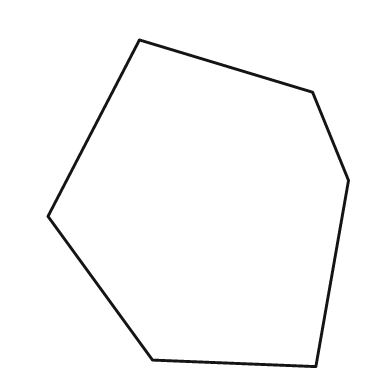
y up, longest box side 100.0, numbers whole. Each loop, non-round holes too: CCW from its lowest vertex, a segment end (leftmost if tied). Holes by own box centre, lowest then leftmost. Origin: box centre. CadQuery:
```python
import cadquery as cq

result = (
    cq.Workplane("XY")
    .moveTo(36.0, -50.0)
    .lineTo(46.0, 7.0)
    .lineTo(35.0, 34.0)
    .lineTo(-18.0, 50.0)
    .lineTo(-46.0, -4.0)
    .lineTo(-14.0, -48.0)
    .close()
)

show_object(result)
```